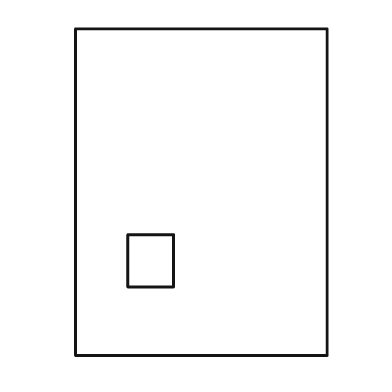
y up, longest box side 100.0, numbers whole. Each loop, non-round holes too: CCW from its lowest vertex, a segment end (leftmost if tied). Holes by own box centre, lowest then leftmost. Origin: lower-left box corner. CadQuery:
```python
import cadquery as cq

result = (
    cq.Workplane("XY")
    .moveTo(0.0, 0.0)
    .lineTo(77.0, 0.0)
    .lineTo(77.0, 100.0)
    .lineTo(0.0, 100.0)
    .close()
    .moveTo(16.0, 21.0)
    .lineTo(30.0, 21.0)
    .lineTo(30.0, 37.0)
    .lineTo(16.0, 37.0)
    .close()
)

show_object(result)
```